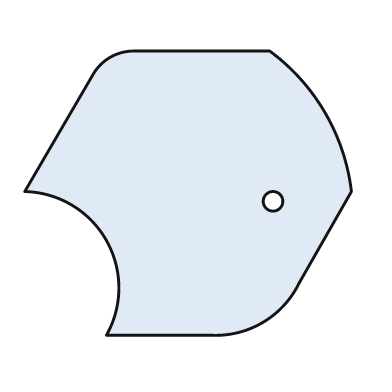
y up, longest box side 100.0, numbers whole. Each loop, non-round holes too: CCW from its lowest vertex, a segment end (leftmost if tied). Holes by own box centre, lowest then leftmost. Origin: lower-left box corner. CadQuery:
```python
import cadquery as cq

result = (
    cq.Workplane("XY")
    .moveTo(25.0, 0.0)
    .lineTo(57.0, 0.0)
    .threePointArc((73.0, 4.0), (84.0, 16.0))
    .lineTo(100.0, 44.0)
    .threePointArc((92.0, 68.0), (75.0, 87.0))
    .lineTo(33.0, 87.0)
    .threePointArc((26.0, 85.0), (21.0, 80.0))
    .lineTo(0.0, 44.0)
    .threePointArc((25.0, 29.0), (25.0, 0.0))
    .close()
    .moveTo(76.0, 41.0)
    .circle(3.0)
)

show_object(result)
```